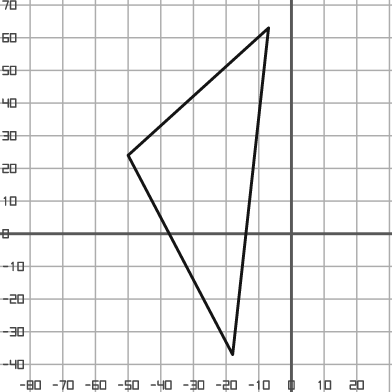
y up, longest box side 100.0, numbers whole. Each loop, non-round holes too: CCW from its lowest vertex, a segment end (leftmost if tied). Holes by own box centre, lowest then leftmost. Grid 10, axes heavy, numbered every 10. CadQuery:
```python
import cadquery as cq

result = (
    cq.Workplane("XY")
    .moveTo(-18.0, -37.0)
    .lineTo(-7.0, 63.0)
    .lineTo(-50.0, 24.0)
    .close()
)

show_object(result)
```